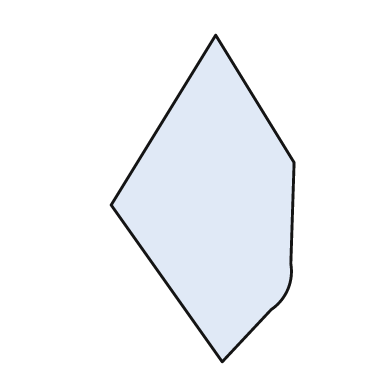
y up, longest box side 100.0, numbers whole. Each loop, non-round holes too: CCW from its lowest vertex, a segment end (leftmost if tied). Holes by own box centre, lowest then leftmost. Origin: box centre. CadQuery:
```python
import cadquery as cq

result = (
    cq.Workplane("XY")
    .moveTo(6.0, -50.0)
    .lineTo(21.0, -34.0)
    .threePointArc((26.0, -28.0), (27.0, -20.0))
    .lineTo(28.0, 11.0)
    .lineTo(4.0, 50.0)
    .lineTo(-28.0, -2.0)
    .close()
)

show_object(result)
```